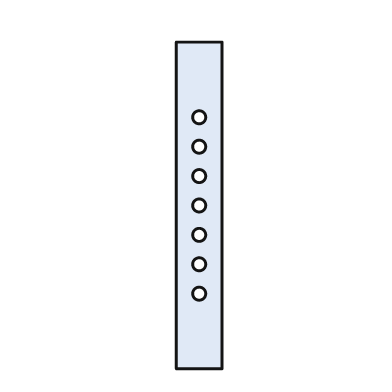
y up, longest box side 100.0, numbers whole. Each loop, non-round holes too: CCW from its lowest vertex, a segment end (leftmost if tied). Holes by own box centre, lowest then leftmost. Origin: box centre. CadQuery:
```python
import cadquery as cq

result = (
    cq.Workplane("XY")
    .moveTo(-7.0, -50.0)
    .lineTo(7.0, -50.0)
    .lineTo(7.0, 50.0)
    .lineTo(-7.0, 50.0)
    .close()
    .moveTo(0.0, -27.0)
    .circle(2.0)
    .moveTo(0.0, -18.0)
    .circle(2.0)
    .moveTo(0.0, -9.0)
    .circle(2.0)
    .moveTo(0.0, 0.0)
    .circle(2.0)
    .moveTo(0.0, 9.0)
    .circle(2.0)
    .moveTo(0.0, 18.0)
    .circle(2.0)
    .moveTo(0.0, 27.0)
    .circle(2.0)
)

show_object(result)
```